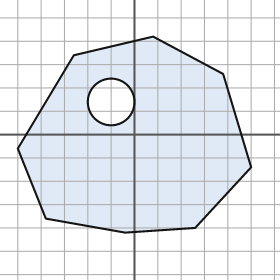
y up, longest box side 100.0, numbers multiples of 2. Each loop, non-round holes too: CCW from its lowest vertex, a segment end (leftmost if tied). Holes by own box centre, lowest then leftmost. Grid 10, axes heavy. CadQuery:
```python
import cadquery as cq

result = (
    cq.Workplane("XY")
    .moveTo(-4.0, -42.0)
    .lineTo(26.0, -40.0)
    .lineTo(50.0, -14.0)
    .lineTo(38.0, 26.0)
    .lineTo(8.0, 42.0)
    .lineTo(-26.0, 34.0)
    .lineTo(-50.0, -6.0)
    .lineTo(-38.0, -36.0)
    .close()
    .moveTo(-10.0, 14.0)
    .circle(10.0)
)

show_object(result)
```